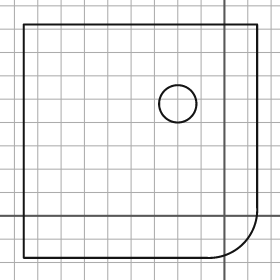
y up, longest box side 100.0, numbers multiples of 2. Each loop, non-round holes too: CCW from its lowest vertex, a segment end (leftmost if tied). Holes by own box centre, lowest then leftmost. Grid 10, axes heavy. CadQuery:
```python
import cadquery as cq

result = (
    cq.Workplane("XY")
    .moveTo(-86.0, -18.0)
    .lineTo(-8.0, -18.0)
    .threePointArc((8.0, -12.0), (14.0, 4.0))
    .lineTo(14.0, 82.0)
    .lineTo(-86.0, 82.0)
    .close()
    .moveTo(-20.0, 48.0)
    .circle(8.0)
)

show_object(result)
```